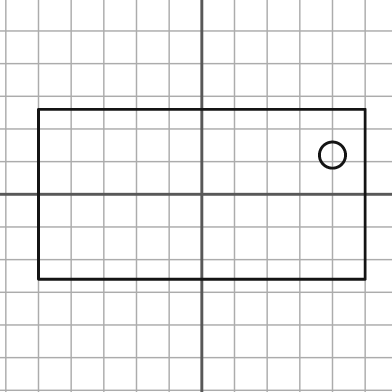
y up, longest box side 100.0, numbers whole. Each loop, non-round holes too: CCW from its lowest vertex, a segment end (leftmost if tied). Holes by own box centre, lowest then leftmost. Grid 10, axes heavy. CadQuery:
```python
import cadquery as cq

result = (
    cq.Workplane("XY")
    .moveTo(-50.0, -26.0)
    .lineTo(50.0, -26.0)
    .lineTo(50.0, 26.0)
    .lineTo(-50.0, 26.0)
    .close()
    .moveTo(40.0, 12.0)
    .circle(4.0)
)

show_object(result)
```